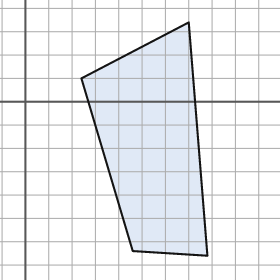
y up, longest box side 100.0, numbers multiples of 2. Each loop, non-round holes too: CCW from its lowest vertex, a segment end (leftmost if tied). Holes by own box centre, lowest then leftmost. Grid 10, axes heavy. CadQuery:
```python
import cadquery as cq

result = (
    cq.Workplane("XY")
    .moveTo(78.0, -66.0)
    .lineTo(70.0, 34.0)
    .lineTo(24.0, 10.0)
    .lineTo(46.0, -64.0)
    .close()
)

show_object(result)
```